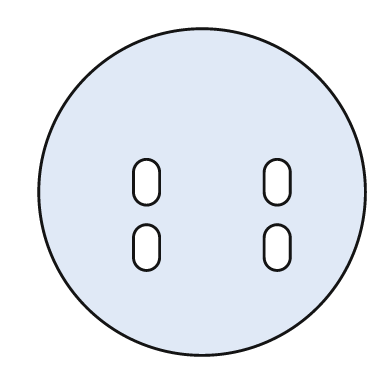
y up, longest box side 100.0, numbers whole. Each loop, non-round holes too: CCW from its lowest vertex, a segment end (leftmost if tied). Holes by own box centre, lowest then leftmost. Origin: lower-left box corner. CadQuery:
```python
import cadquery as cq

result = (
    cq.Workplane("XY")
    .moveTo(50.0, 50.0)
    .circle(50.0)
    .moveTo(29.0, 30.0)
    .threePointArc((33.0, 26.0), (37.0, 30.0))
    .lineTo(37.0, 36.0)
    .threePointArc((33.0, 40.0), (29.0, 36.0))
    .close()
    .moveTo(69.0, 30.0)
    .threePointArc((73.0, 26.0), (77.0, 30.0))
    .lineTo(77.0, 36.0)
    .threePointArc((73.0, 40.0), (69.0, 36.0))
    .close()
    .moveTo(29.0, 50.0)
    .threePointArc((33.0, 46.0), (37.0, 50.0))
    .lineTo(37.0, 56.0)
    .threePointArc((33.0, 60.0), (29.0, 56.0))
    .close()
    .moveTo(69.0, 50.0)
    .threePointArc((73.0, 46.0), (77.0, 50.0))
    .lineTo(77.0, 56.0)
    .threePointArc((73.0, 60.0), (69.0, 56.0))
    .close()
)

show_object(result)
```